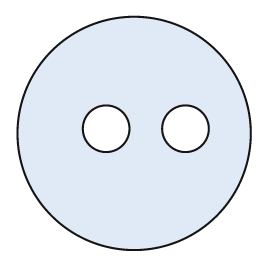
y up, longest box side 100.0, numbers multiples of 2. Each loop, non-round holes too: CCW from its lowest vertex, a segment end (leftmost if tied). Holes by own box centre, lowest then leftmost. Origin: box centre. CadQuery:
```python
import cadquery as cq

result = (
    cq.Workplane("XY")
    .moveTo(0.0, 0.0)
    .circle(50.0)
    .moveTo(-12.0, 2.0)
    .circle(10.0)
    .moveTo(22.0, 2.0)
    .circle(10.0)
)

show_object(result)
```